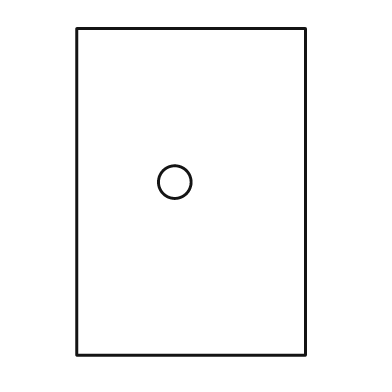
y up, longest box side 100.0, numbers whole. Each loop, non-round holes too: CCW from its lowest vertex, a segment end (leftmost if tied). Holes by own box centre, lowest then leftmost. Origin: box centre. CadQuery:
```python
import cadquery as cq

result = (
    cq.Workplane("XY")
    .moveTo(-35.0, -50.0)
    .lineTo(35.0, -50.0)
    .lineTo(35.0, 50.0)
    .lineTo(-35.0, 50.0)
    .close()
    .moveTo(-5.0, 3.0)
    .circle(5.0)
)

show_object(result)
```